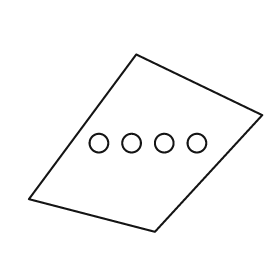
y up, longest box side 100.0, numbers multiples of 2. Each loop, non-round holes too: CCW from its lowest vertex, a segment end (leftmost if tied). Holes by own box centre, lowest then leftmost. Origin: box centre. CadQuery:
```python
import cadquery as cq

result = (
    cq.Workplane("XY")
    .moveTo(4.0, -38.0)
    .lineTo(50.0, 12.0)
    .lineTo(-4.0, 38.0)
    .lineTo(-50.0, -24.0)
    .close()
    .moveTo(-20.0, 0.0)
    .circle(4.0)
    .moveTo(-6.0, 0.0)
    .circle(4.0)
    .moveTo(8.0, 0.0)
    .circle(4.0)
    .moveTo(22.0, 0.0)
    .circle(4.0)
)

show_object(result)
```